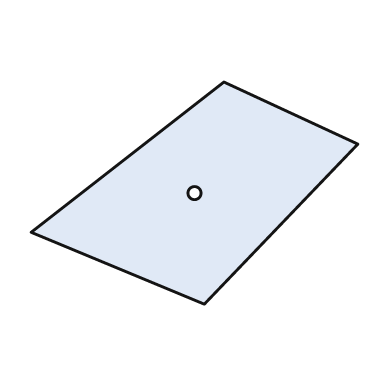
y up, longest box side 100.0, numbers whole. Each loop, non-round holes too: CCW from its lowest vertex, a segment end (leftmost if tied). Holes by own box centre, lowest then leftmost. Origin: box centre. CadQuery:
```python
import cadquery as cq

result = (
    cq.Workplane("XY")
    .moveTo(3.0, -34.0)
    .lineTo(50.0, 15.0)
    .lineTo(9.0, 34.0)
    .lineTo(-50.0, -12.0)
    .close()
    .moveTo(0.0, 0.0)
    .circle(2.0)
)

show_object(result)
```